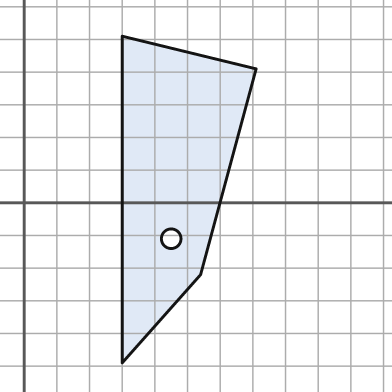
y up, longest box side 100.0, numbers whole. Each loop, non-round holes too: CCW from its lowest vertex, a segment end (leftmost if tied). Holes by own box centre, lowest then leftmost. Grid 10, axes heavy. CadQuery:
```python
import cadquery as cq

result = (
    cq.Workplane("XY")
    .moveTo(30.0, -49.0)
    .lineTo(54.0, -22.0)
    .lineTo(71.0, 41.0)
    .lineTo(30.0, 51.0)
    .close()
    .moveTo(45.0, -11.0)
    .circle(3.0)
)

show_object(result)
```